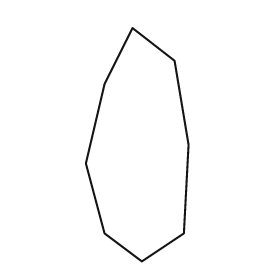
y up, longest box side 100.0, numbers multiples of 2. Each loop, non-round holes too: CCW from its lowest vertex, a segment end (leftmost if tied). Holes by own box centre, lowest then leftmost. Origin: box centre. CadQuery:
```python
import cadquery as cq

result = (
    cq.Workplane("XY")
    .moveTo(2.0, -50.0)
    .lineTo(20.0, -38.0)
    .lineTo(22.0, 0.0)
    .lineTo(16.0, 36.0)
    .lineTo(-2.0, 50.0)
    .lineTo(-14.0, 26.0)
    .lineTo(-22.0, -8.0)
    .lineTo(-14.0, -38.0)
    .close()
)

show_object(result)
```